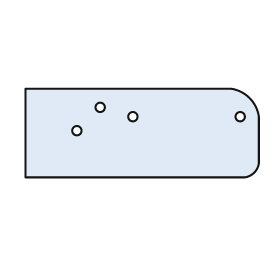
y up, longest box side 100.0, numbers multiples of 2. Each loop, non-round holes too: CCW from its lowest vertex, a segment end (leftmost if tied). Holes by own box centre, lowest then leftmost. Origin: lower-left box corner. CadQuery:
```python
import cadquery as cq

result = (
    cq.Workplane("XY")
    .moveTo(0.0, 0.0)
    .lineTo(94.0, 0.0)
    .threePointArc((98.0, 2.0), (100.0, 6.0))
    .lineTo(100.0, 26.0)
    .threePointArc((96.0, 34.0), (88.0, 38.0))
    .lineTo(0.0, 38.0)
    .close()
    .moveTo(22.0, 20.0)
    .circle(2.0)
    .moveTo(46.0, 26.0)
    .circle(2.0)
    .moveTo(92.0, 26.0)
    .circle(2.0)
    .moveTo(32.0, 30.0)
    .circle(2.0)
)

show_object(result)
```